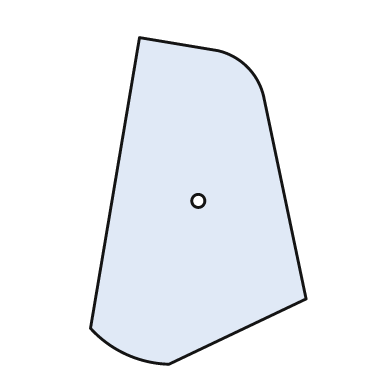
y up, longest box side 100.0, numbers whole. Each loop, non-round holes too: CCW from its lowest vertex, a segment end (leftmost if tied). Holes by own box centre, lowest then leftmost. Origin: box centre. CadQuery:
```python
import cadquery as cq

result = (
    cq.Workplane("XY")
    .moveTo(-9.0, -50.0)
    .lineTo(33.0, -30.0)
    .lineTo(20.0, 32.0)
    .threePointArc((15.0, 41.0), (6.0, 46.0))
    .lineTo(-18.0, 50.0)
    .lineTo(-33.0, -39.0)
    .threePointArc((-22.0, -47.0), (-9.0, -50.0))
    .close()
    .moveTo(0.0, 0.0)
    .circle(2.0)
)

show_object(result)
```